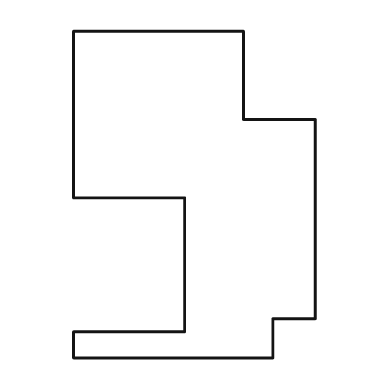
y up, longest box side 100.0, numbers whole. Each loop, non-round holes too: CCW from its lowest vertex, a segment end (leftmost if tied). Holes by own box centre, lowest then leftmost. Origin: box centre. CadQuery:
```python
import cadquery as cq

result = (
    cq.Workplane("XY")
    .moveTo(-37.0, -50.0)
    .lineTo(24.0, -50.0)
    .lineTo(24.0, -38.0)
    .lineTo(37.0, -38.0)
    .lineTo(37.0, 23.0)
    .lineTo(15.0, 23.0)
    .lineTo(15.0, 50.0)
    .lineTo(-37.0, 50.0)
    .lineTo(-37.0, -1.0)
    .lineTo(-3.0, -1.0)
    .lineTo(-3.0, -42.0)
    .lineTo(-37.0, -42.0)
    .close()
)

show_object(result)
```